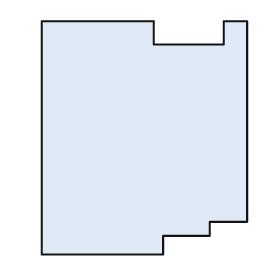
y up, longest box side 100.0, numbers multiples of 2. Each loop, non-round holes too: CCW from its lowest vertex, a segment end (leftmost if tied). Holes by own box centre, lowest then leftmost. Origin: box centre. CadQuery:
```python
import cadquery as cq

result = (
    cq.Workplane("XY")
    .moveTo(-44.0, -50.0)
    .lineTo(8.0, -50.0)
    .lineTo(8.0, -42.0)
    .lineTo(28.0, -42.0)
    .lineTo(28.0, -36.0)
    .lineTo(44.0, -36.0)
    .lineTo(44.0, 50.0)
    .lineTo(34.0, 50.0)
    .lineTo(34.0, 40.0)
    .lineTo(4.0, 40.0)
    .lineTo(4.0, 50.0)
    .lineTo(-44.0, 50.0)
    .close()
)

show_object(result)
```